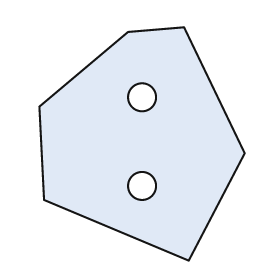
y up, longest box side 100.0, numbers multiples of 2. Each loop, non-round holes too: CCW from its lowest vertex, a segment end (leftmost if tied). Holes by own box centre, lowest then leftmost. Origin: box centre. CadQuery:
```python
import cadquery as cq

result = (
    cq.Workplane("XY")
    .moveTo(20.0, -50.0)
    .lineTo(44.0, -4.0)
    .lineTo(18.0, 50.0)
    .lineTo(-6.0, 48.0)
    .lineTo(-44.0, 16.0)
    .lineTo(-42.0, -24.0)
    .close()
    .moveTo(0.0, -18.0)
    .circle(6.0)
    .moveTo(0.0, 20.0)
    .circle(6.0)
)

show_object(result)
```